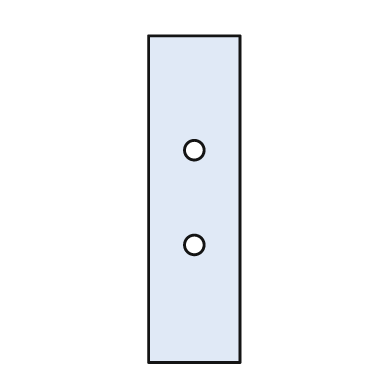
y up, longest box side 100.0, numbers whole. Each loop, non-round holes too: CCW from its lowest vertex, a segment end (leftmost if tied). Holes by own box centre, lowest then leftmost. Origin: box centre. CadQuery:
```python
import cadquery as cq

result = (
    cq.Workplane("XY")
    .moveTo(-14.0, -50.0)
    .lineTo(14.0, -50.0)
    .lineTo(14.0, 50.0)
    .lineTo(-14.0, 50.0)
    .close()
    .moveTo(0.0, -14.0)
    .circle(3.0)
    .moveTo(0.0, 15.0)
    .circle(3.0)
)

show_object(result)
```